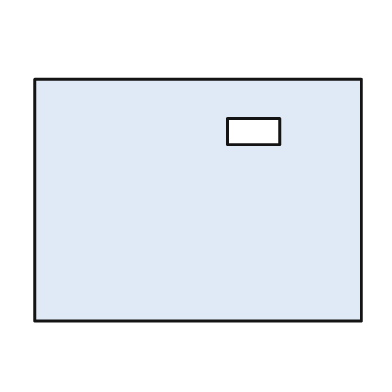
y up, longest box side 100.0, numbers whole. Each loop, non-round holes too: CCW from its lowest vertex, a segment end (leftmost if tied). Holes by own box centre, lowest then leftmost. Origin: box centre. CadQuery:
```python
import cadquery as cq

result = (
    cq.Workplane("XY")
    .moveTo(-50.0, -37.0)
    .lineTo(50.0, -37.0)
    .lineTo(50.0, 37.0)
    .lineTo(-50.0, 37.0)
    .close()
    .moveTo(9.0, 17.0)
    .lineTo(25.0, 17.0)
    .lineTo(25.0, 25.0)
    .lineTo(9.0, 25.0)
    .close()
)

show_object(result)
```